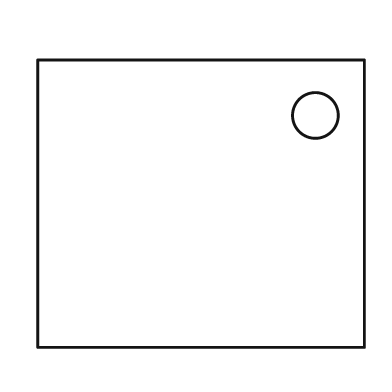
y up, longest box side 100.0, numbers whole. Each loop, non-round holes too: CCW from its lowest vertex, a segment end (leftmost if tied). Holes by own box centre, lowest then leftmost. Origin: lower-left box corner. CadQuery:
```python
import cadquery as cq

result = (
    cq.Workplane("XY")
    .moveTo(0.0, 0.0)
    .lineTo(100.0, 0.0)
    .lineTo(100.0, 88.0)
    .lineTo(0.0, 88.0)
    .close()
    .moveTo(85.0, 71.0)
    .circle(7.0)
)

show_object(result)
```